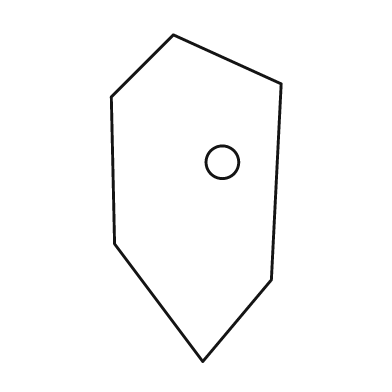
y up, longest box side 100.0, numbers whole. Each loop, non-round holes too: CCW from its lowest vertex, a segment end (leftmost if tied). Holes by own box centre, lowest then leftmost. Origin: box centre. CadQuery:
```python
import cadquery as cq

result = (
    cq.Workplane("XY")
    .moveTo(2.0, -50.0)
    .lineTo(23.0, -25.0)
    .lineTo(26.0, 35.0)
    .lineTo(-7.0, 50.0)
    .lineTo(-26.0, 31.0)
    .lineTo(-25.0, -14.0)
    .close()
    .moveTo(8.0, 11.0)
    .circle(5.0)
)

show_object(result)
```